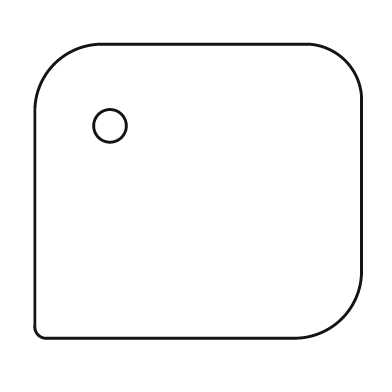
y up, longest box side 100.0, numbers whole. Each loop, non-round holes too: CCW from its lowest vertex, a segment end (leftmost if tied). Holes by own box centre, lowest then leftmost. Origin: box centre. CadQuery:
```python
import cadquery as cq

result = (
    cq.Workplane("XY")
    .moveTo(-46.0, -45.0)
    .lineTo(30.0, -45.0)
    .threePointArc((44.0, -39.0), (50.0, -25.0))
    .lineTo(50.0, 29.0)
    .threePointArc((45.0, 40.0), (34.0, 45.0))
    .lineTo(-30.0, 45.0)
    .threePointArc((-44.0, 39.0), (-50.0, 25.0))
    .lineTo(-50.0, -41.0)
    .threePointArc((-49.0, -44.0), (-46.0, -45.0))
    .close()
    .moveTo(-27.0, 20.0)
    .circle(5.0)
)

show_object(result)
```